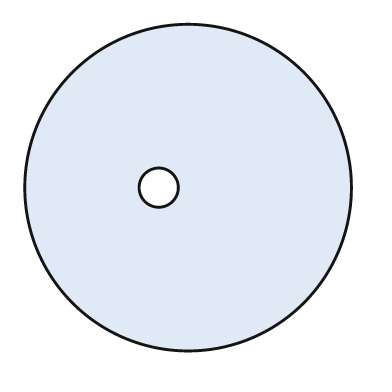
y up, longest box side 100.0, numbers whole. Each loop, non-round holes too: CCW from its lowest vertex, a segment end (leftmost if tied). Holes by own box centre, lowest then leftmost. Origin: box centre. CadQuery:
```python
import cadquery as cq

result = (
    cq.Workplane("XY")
    .moveTo(0.0, 0.0)
    .circle(50.0)
    .moveTo(-9.0, 0.0)
    .circle(6.0)
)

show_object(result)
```